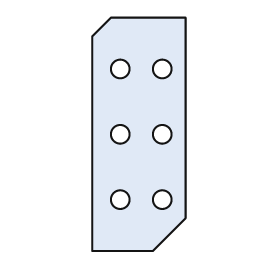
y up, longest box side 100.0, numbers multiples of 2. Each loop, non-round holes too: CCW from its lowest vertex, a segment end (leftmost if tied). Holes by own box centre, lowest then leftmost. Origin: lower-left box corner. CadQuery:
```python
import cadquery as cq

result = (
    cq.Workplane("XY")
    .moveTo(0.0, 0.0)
    .lineTo(26.0, 0.0)
    .lineTo(40.0, 14.0)
    .lineTo(40.0, 100.0)
    .lineTo(8.0, 100.0)
    .lineTo(0.0, 92.0)
    .close()
    .moveTo(12.0, 22.0)
    .circle(4.0)
    .moveTo(30.0, 22.0)
    .circle(4.0)
    .moveTo(12.0, 50.0)
    .circle(4.0)
    .moveTo(30.0, 50.0)
    .circle(4.0)
    .moveTo(12.0, 78.0)
    .circle(4.0)
    .moveTo(30.0, 78.0)
    .circle(4.0)
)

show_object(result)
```